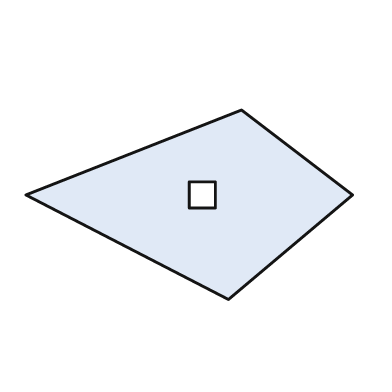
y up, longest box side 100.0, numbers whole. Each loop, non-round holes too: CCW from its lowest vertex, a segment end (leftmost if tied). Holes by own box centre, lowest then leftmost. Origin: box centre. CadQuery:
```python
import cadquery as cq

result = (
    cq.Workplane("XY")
    .moveTo(12.0, -29.0)
    .lineTo(50.0, 3.0)
    .lineTo(16.0, 29.0)
    .lineTo(-50.0, 3.0)
    .close()
    .moveTo(0.0, -1.0)
    .lineTo(8.0, -1.0)
    .lineTo(8.0, 7.0)
    .lineTo(0.0, 7.0)
    .close()
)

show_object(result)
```